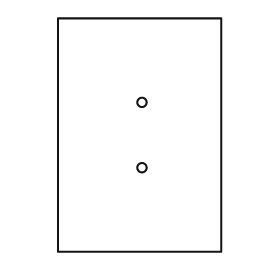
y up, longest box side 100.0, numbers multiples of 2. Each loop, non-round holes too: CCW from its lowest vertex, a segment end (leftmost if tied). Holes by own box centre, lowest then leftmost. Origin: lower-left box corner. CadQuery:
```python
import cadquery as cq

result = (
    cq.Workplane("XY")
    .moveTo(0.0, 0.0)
    .lineTo(70.0, 0.0)
    .lineTo(70.0, 100.0)
    .lineTo(0.0, 100.0)
    .close()
    .moveTo(36.0, 36.0)
    .circle(2.0)
    .moveTo(36.0, 64.0)
    .circle(2.0)
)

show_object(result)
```